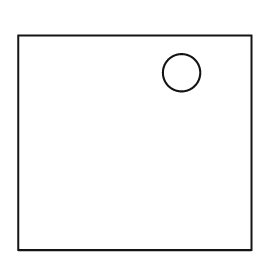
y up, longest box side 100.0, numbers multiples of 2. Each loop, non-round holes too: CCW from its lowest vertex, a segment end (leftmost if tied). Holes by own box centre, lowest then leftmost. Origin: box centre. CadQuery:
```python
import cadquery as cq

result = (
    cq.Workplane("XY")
    .moveTo(-50.0, -46.0)
    .lineTo(50.0, -46.0)
    .lineTo(50.0, 46.0)
    .lineTo(-50.0, 46.0)
    .close()
    .moveTo(20.0, 30.0)
    .circle(8.0)
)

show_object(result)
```